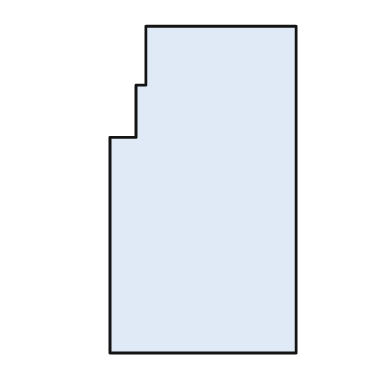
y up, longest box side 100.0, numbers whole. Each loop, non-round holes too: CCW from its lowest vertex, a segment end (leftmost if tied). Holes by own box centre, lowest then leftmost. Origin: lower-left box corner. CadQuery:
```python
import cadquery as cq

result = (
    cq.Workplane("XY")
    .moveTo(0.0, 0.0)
    .lineTo(57.0, 0.0)
    .lineTo(57.0, 100.0)
    .lineTo(11.0, 100.0)
    .lineTo(11.0, 82.0)
    .lineTo(8.0, 82.0)
    .lineTo(8.0, 66.0)
    .lineTo(0.0, 66.0)
    .close()
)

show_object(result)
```